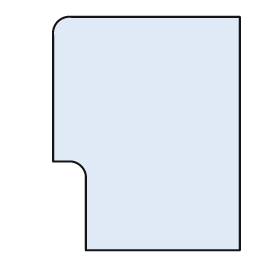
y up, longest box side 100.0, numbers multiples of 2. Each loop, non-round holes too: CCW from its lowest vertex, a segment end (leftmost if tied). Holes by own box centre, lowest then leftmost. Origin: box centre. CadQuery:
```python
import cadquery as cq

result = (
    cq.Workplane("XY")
    .moveTo(-26.0, -50.0)
    .lineTo(40.0, -50.0)
    .lineTo(40.0, 50.0)
    .lineTo(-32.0, 50.0)
    .threePointArc((-38.0, 48.0), (-40.0, 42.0))
    .lineTo(-40.0, -12.0)
    .lineTo(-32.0, -12.0)
    .threePointArc((-28.0, -14.0), (-26.0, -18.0))
    .close()
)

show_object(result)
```